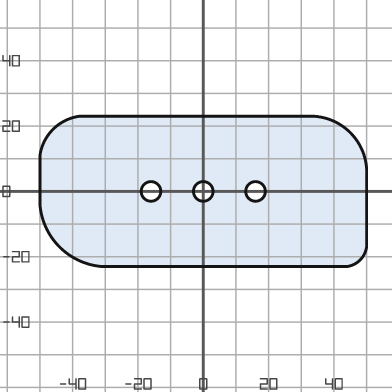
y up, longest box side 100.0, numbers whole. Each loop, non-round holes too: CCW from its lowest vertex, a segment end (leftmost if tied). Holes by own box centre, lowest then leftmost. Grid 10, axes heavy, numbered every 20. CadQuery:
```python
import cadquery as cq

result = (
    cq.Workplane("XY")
    .moveTo(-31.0, -23.0)
    .lineTo(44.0, -23.0)
    .threePointArc((48.0, -21.0), (50.0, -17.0))
    .lineTo(50.0, 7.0)
    .threePointArc((45.0, 18.0), (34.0, 23.0))
    .lineTo(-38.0, 23.0)
    .threePointArc((-46.0, 19.0), (-50.0, 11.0))
    .lineTo(-50.0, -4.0)
    .threePointArc((-44.0, -17.0), (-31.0, -23.0))
    .close()
    .moveTo(-16.0, 0.0)
    .circle(3.0)
    .moveTo(0.0, 0.0)
    .circle(3.0)
    .moveTo(16.0, 0.0)
    .circle(3.0)
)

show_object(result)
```